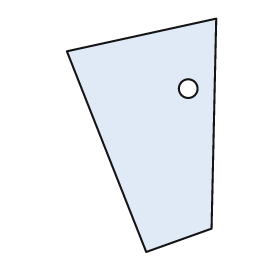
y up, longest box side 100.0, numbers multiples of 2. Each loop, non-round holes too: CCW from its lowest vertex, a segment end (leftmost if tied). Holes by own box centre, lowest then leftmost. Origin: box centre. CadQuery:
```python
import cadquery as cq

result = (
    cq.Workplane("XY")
    .moveTo(2.0, -50.0)
    .lineTo(30.0, -40.0)
    .lineTo(32.0, 50.0)
    .lineTo(-32.0, 36.0)
    .close()
    .moveTo(20.0, 20.0)
    .circle(4.0)
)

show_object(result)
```